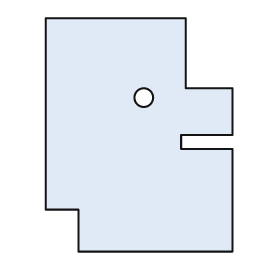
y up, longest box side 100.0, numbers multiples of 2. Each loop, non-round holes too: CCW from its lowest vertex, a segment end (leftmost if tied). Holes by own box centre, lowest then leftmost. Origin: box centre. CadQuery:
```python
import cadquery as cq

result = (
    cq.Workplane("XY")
    .moveTo(-26.0, -50.0)
    .lineTo(40.0, -50.0)
    .lineTo(40.0, -6.0)
    .lineTo(18.0, -6.0)
    .lineTo(18.0, 0.0)
    .lineTo(40.0, 0.0)
    .lineTo(40.0, 20.0)
    .lineTo(20.0, 20.0)
    .lineTo(20.0, 50.0)
    .lineTo(-40.0, 50.0)
    .lineTo(-40.0, -32.0)
    .lineTo(-26.0, -32.0)
    .close()
    .moveTo(2.0, 16.0)
    .circle(4.0)
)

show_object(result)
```